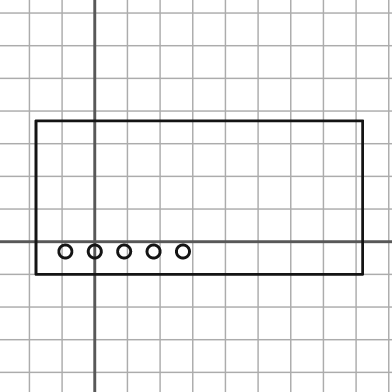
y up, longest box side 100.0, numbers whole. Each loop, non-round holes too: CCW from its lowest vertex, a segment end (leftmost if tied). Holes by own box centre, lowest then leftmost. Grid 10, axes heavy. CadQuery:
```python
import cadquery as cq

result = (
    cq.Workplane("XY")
    .moveTo(-18.0, -10.0)
    .lineTo(82.0, -10.0)
    .lineTo(82.0, 37.0)
    .lineTo(-18.0, 37.0)
    .close()
    .moveTo(-9.0, -3.0)
    .circle(2.0)
    .moveTo(0.0, -3.0)
    .circle(2.0)
    .moveTo(9.0, -3.0)
    .circle(2.0)
    .moveTo(18.0, -3.0)
    .circle(2.0)
    .moveTo(27.0, -3.0)
    .circle(2.0)
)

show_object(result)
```